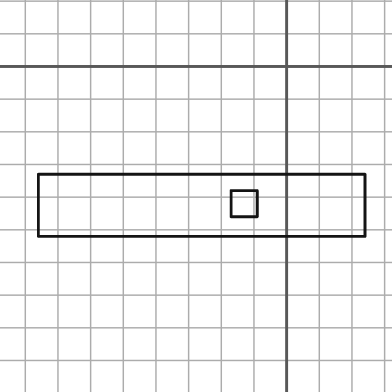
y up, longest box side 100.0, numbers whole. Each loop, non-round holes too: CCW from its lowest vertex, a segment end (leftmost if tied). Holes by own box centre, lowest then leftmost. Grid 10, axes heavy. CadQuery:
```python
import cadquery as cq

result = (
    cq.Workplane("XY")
    .moveTo(-76.0, -52.0)
    .lineTo(24.0, -52.0)
    .lineTo(24.0, -33.0)
    .lineTo(-76.0, -33.0)
    .close()
    .moveTo(-17.0, -46.0)
    .lineTo(-9.0, -46.0)
    .lineTo(-9.0, -38.0)
    .lineTo(-17.0, -38.0)
    .close()
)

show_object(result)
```